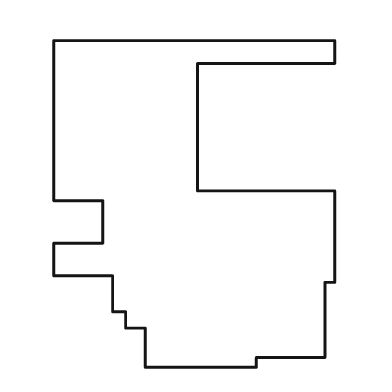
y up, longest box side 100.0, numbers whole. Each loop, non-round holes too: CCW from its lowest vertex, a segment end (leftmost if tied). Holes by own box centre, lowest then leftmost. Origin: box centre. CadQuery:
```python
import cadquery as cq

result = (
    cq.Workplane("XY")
    .moveTo(-15.0, -50.0)
    .lineTo(19.0, -50.0)
    .lineTo(19.0, -47.0)
    .lineTo(40.0, -47.0)
    .lineTo(40.0, -24.0)
    .lineTo(43.0, -24.0)
    .lineTo(43.0, 4.0)
    .lineTo(1.0, 4.0)
    .lineTo(1.0, 43.0)
    .lineTo(43.0, 43.0)
    .lineTo(43.0, 50.0)
    .lineTo(-43.0, 50.0)
    .lineTo(-43.0, 1.0)
    .lineTo(-28.0, 1.0)
    .lineTo(-28.0, -12.0)
    .lineTo(-43.0, -12.0)
    .lineTo(-43.0, -22.0)
    .lineTo(-25.0, -22.0)
    .lineTo(-25.0, -33.0)
    .lineTo(-21.0, -33.0)
    .lineTo(-21.0, -38.0)
    .lineTo(-15.0, -38.0)
    .close()
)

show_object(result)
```